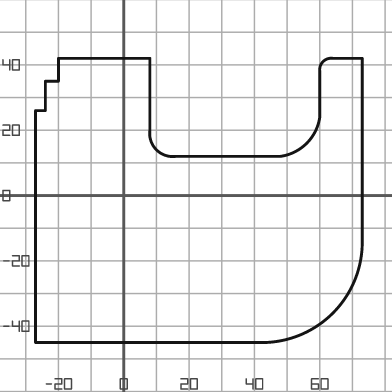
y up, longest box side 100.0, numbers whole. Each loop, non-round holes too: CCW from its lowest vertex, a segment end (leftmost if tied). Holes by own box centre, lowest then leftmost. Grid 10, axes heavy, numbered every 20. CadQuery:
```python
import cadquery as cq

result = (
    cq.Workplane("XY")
    .moveTo(-27.0, -45.0)
    .lineTo(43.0, -45.0)
    .threePointArc((64.0, -36.0), (73.0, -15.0))
    .lineTo(73.0, 42.0)
    .lineTo(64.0, 42.0)
    .threePointArc((61.0, 41.0), (60.0, 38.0))
    .lineTo(60.0, 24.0)
    .threePointArc((56.0, 16.0), (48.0, 12.0))
    .lineTo(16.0, 12.0)
    .threePointArc((10.0, 14.0), (8.0, 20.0))
    .lineTo(8.0, 42.0)
    .lineTo(-20.0, 42.0)
    .lineTo(-20.0, 35.0)
    .lineTo(-24.0, 35.0)
    .lineTo(-24.0, 26.0)
    .lineTo(-27.0, 26.0)
    .close()
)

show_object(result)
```